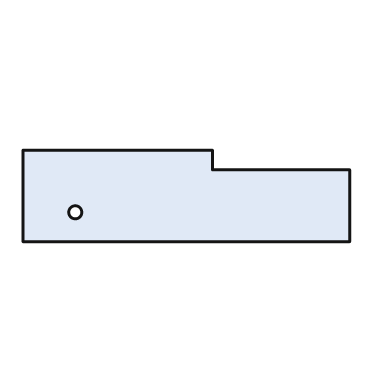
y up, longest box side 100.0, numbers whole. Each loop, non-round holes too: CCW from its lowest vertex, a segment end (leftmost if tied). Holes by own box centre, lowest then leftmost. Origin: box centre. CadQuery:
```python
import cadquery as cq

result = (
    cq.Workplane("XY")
    .moveTo(-50.0, -14.0)
    .lineTo(50.0, -14.0)
    .lineTo(50.0, 8.0)
    .lineTo(8.0, 8.0)
    .lineTo(8.0, 14.0)
    .lineTo(-50.0, 14.0)
    .close()
    .moveTo(-34.0, -5.0)
    .circle(2.0)
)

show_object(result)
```